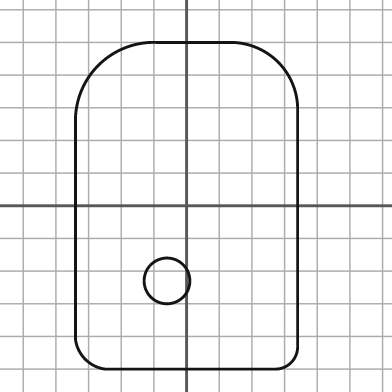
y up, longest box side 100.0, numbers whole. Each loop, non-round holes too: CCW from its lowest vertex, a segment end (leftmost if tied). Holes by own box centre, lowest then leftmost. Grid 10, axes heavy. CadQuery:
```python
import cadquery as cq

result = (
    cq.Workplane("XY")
    .moveTo(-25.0, -50.0)
    .lineTo(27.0, -50.0)
    .threePointArc((32.0, -48.0), (34.0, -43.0))
    .lineTo(34.0, 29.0)
    .threePointArc((28.0, 44.0), (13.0, 50.0))
    .lineTo(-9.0, 50.0)
    .threePointArc((-27.0, 43.0), (-34.0, 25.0))
    .lineTo(-34.0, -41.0)
    .threePointArc((-31.0, -47.0), (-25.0, -50.0))
    .close()
    .moveTo(-6.0, -23.0)
    .circle(7.0)
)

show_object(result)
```